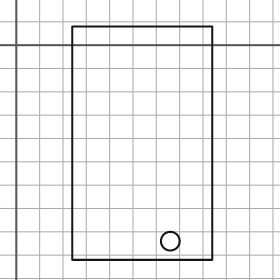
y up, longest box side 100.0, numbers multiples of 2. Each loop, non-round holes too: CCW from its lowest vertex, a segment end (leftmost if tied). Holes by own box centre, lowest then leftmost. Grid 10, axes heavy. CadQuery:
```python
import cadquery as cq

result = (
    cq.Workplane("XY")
    .moveTo(24.0, -92.0)
    .lineTo(84.0, -92.0)
    .lineTo(84.0, 8.0)
    .lineTo(24.0, 8.0)
    .close()
    .moveTo(66.0, -84.0)
    .circle(4.0)
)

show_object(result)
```